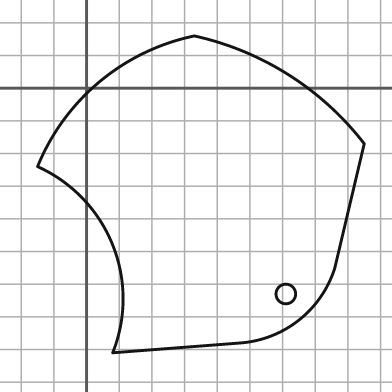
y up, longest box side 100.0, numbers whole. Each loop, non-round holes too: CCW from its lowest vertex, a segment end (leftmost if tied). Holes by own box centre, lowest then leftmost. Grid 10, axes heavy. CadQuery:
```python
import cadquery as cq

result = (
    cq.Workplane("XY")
    .moveTo(8.0, -81.0)
    .lineTo(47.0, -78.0)
    .threePointArc((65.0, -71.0), (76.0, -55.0))
    .lineTo(85.0, -17.0)
    .threePointArc((62.0, 4.0), (33.0, 16.0))
    .threePointArc((4.0, 2.0), (-15.0, -24.0))
    .threePointArc((8.0, -48.0), (8.0, -81.0))
    .close()
    .moveTo(61.0, -63.0)
    .circle(3.0)
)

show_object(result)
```